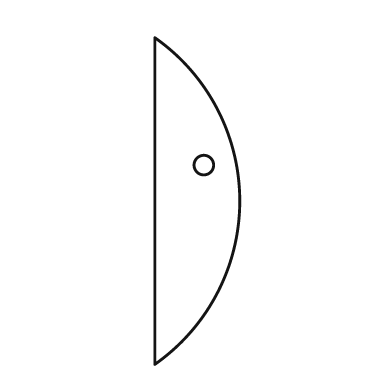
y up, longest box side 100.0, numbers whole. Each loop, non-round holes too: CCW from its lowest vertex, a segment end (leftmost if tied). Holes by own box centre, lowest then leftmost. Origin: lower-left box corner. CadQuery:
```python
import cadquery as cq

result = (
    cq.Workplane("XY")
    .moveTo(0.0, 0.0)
    .threePointArc((26.0, 50.0), (0.0, 100.0))
    .close()
    .moveTo(15.0, 61.0)
    .circle(3.0)
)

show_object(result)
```